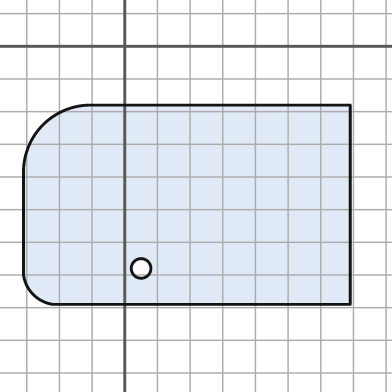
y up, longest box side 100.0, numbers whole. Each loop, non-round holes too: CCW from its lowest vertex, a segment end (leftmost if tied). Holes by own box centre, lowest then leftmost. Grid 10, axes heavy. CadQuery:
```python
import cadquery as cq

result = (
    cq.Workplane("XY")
    .moveTo(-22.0, -79.0)
    .lineTo(69.0, -79.0)
    .lineTo(69.0, -18.0)
    .lineTo(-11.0, -18.0)
    .threePointArc((-25.0, -24.0), (-31.0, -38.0))
    .lineTo(-31.0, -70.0)
    .threePointArc((-28.0, -76.0), (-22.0, -79.0))
    .close()
    .moveTo(5.0, -68.0)
    .circle(3.0)
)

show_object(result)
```